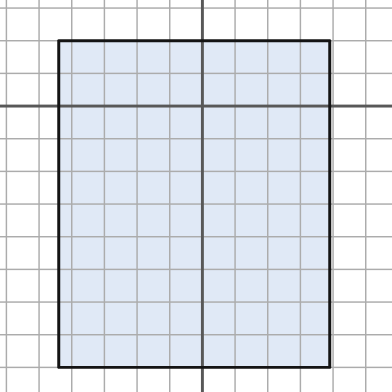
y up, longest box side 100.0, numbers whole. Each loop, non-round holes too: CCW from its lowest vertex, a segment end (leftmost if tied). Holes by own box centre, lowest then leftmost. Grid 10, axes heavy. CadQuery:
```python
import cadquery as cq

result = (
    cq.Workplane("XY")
    .moveTo(-44.0, -80.0)
    .lineTo(39.0, -80.0)
    .lineTo(39.0, 20.0)
    .lineTo(-44.0, 20.0)
    .close()
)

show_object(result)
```